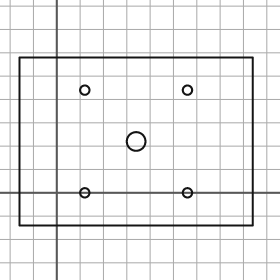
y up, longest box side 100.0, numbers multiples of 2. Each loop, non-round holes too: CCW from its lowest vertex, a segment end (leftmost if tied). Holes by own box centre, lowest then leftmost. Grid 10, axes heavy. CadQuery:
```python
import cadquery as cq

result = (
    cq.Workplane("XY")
    .moveTo(-16.0, -14.0)
    .lineTo(84.0, -14.0)
    .lineTo(84.0, 58.0)
    .lineTo(-16.0, 58.0)
    .close()
    .moveTo(12.0, 0.0)
    .circle(2.0)
    .moveTo(56.0, 0.0)
    .circle(2.0)
    .moveTo(34.0, 22.0)
    .circle(4.0)
    .moveTo(12.0, 44.0)
    .circle(2.0)
    .moveTo(56.0, 44.0)
    .circle(2.0)
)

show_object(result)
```